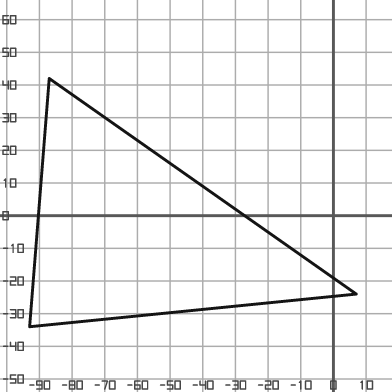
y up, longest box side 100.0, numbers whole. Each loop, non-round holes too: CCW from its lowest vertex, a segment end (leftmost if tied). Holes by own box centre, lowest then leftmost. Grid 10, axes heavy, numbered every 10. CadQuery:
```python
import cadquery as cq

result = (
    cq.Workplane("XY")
    .moveTo(-93.0, -34.0)
    .lineTo(7.0, -24.0)
    .lineTo(-87.0, 42.0)
    .close()
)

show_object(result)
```